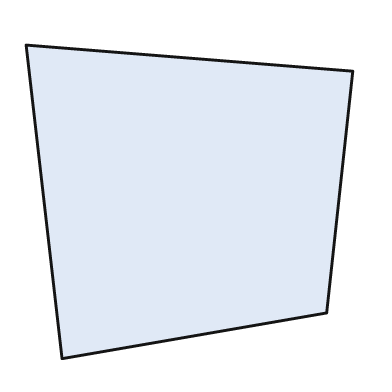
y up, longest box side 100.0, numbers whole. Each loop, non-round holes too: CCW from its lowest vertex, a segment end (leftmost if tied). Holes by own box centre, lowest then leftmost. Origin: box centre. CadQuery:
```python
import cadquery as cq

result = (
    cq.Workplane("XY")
    .moveTo(-39.0, -48.0)
    .lineTo(42.0, -34.0)
    .lineTo(50.0, 40.0)
    .lineTo(-50.0, 48.0)
    .close()
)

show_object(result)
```